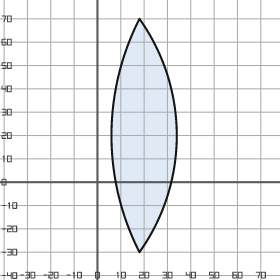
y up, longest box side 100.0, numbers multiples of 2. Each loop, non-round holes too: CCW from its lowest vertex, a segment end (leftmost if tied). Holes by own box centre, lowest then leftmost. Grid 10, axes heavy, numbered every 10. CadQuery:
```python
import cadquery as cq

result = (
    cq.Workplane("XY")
    .moveTo(18.0, -30.0)
    .threePointArc((34.0, 20.0), (18.0, 70.0))
    .threePointArc((6.0, 20.0), (18.0, -30.0))
    .close()
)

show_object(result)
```